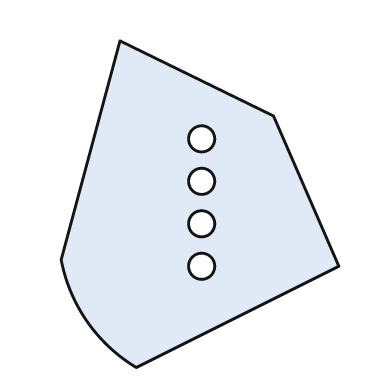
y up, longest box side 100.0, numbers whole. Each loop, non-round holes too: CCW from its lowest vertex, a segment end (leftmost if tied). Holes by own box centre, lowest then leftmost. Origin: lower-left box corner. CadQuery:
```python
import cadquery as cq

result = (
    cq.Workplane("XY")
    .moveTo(23.0, 0.0)
    .lineTo(85.0, 31.0)
    .lineTo(65.0, 77.0)
    .lineTo(18.0, 100.0)
    .lineTo(0.0, 33.0)
    .threePointArc((8.0, 14.0), (23.0, 0.0))
    .close()
    .moveTo(43.0, 31.0)
    .circle(4.0)
    .moveTo(43.0, 44.0)
    .circle(4.0)
    .moveTo(43.0, 57.0)
    .circle(4.0)
    .moveTo(43.0, 70.0)
    .circle(4.0)
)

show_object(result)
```